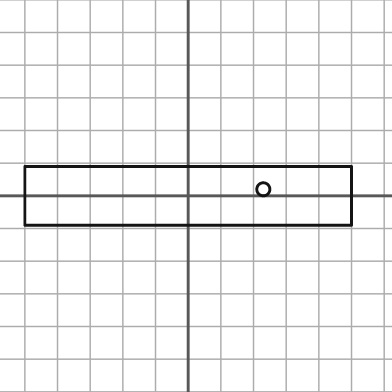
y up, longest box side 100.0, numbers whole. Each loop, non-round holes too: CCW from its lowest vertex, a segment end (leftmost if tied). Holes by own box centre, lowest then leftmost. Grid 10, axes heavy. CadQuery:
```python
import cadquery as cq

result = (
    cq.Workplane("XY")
    .moveTo(-50.0, -9.0)
    .lineTo(50.0, -9.0)
    .lineTo(50.0, 9.0)
    .lineTo(-50.0, 9.0)
    .close()
    .moveTo(23.0, 2.0)
    .circle(2.0)
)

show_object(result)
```